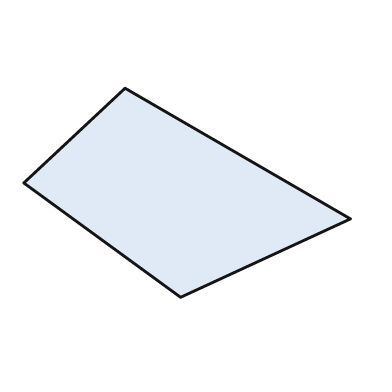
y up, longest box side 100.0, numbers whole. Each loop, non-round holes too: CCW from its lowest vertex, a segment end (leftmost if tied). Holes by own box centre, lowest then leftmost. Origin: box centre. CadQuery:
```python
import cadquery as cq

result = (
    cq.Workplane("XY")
    .moveTo(-2.0, -32.0)
    .lineTo(50.0, -8.0)
    .lineTo(-19.0, 32.0)
    .lineTo(-50.0, 3.0)
    .close()
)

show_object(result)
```